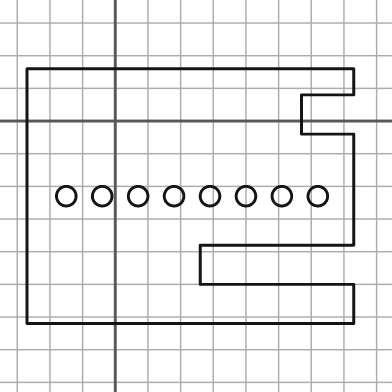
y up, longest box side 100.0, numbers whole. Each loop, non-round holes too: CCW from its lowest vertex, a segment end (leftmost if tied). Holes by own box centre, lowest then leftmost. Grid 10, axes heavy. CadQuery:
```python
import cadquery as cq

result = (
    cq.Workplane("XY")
    .moveTo(-27.0, -62.0)
    .lineTo(73.0, -62.0)
    .lineTo(73.0, -50.0)
    .lineTo(26.0, -50.0)
    .lineTo(26.0, -38.0)
    .lineTo(73.0, -38.0)
    .lineTo(73.0, -4.0)
    .lineTo(57.0, -4.0)
    .lineTo(57.0, 8.0)
    .lineTo(73.0, 8.0)
    .lineTo(73.0, 16.0)
    .lineTo(-27.0, 16.0)
    .close()
    .moveTo(-15.0, -23.0)
    .circle(3.0)
    .moveTo(-4.0, -23.0)
    .circle(3.0)
    .moveTo(7.0, -23.0)
    .circle(3.0)
    .moveTo(18.0, -23.0)
    .circle(3.0)
    .moveTo(29.0, -23.0)
    .circle(3.0)
    .moveTo(40.0, -23.0)
    .circle(3.0)
    .moveTo(51.0, -23.0)
    .circle(3.0)
    .moveTo(62.0, -23.0)
    .circle(3.0)
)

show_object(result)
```